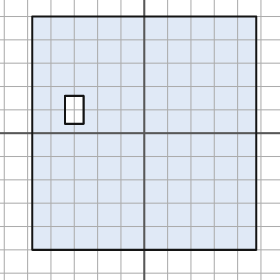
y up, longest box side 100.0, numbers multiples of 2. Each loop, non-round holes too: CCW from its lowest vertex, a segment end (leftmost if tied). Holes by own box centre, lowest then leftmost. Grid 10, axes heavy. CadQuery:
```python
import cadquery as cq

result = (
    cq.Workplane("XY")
    .moveTo(-48.0, -50.0)
    .lineTo(48.0, -50.0)
    .lineTo(48.0, 50.0)
    .lineTo(-48.0, 50.0)
    .close()
    .moveTo(-34.0, 4.0)
    .lineTo(-26.0, 4.0)
    .lineTo(-26.0, 16.0)
    .lineTo(-34.0, 16.0)
    .close()
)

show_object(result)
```